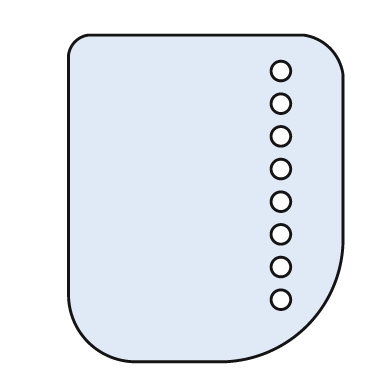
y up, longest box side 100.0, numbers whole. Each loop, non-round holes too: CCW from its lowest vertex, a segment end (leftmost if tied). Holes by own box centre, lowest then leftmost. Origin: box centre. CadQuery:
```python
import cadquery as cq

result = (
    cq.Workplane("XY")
    .moveTo(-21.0, -50.0)
    .lineTo(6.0, -50.0)
    .threePointArc((31.0, -39.0), (42.0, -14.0))
    .lineTo(42.0, 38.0)
    .threePointArc((38.0, 46.0), (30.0, 50.0))
    .lineTo(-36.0, 50.0)
    .threePointArc((-40.0, 48.0), (-42.0, 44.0))
    .lineTo(-42.0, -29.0)
    .threePointArc((-36.0, -44.0), (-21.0, -50.0))
    .close()
    .moveTo(23.0, -31.0)
    .circle(3.0)
    .moveTo(23.0, -21.0)
    .circle(3.0)
    .moveTo(23.0, -11.0)
    .circle(3.0)
    .moveTo(23.0, -1.0)
    .circle(3.0)
    .moveTo(23.0, 9.0)
    .circle(3.0)
    .moveTo(23.0, 19.0)
    .circle(3.0)
    .moveTo(23.0, 29.0)
    .circle(3.0)
    .moveTo(23.0, 39.0)
    .circle(3.0)
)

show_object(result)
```